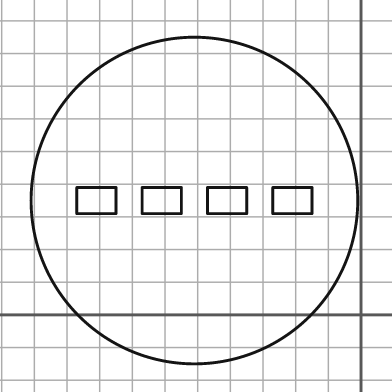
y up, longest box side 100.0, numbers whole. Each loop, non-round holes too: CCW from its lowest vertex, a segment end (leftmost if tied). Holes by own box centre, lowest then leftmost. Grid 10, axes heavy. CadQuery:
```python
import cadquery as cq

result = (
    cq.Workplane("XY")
    .moveTo(-51.0, 35.0)
    .circle(50.0)
    .moveTo(-87.0, 31.0)
    .lineTo(-75.0, 31.0)
    .lineTo(-75.0, 39.0)
    .lineTo(-87.0, 39.0)
    .close()
    .moveTo(-67.0, 31.0)
    .lineTo(-55.0, 31.0)
    .lineTo(-55.0, 39.0)
    .lineTo(-67.0, 39.0)
    .close()
    .moveTo(-47.0, 31.0)
    .lineTo(-35.0, 31.0)
    .lineTo(-35.0, 39.0)
    .lineTo(-47.0, 39.0)
    .close()
    .moveTo(-27.0, 31.0)
    .lineTo(-15.0, 31.0)
    .lineTo(-15.0, 39.0)
    .lineTo(-27.0, 39.0)
    .close()
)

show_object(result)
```